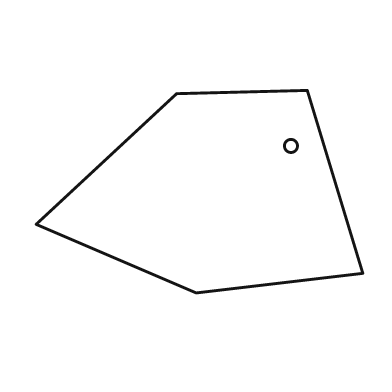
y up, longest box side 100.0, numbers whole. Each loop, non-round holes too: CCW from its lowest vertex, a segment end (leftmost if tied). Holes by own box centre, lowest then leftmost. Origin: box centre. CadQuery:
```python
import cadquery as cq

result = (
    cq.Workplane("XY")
    .moveTo(-1.0, -31.0)
    .lineTo(50.0, -25.0)
    .lineTo(33.0, 31.0)
    .lineTo(-7.0, 30.0)
    .lineTo(-50.0, -10.0)
    .close()
    .moveTo(28.0, 14.0)
    .circle(2.0)
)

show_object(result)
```